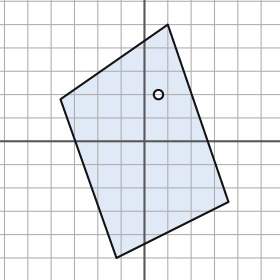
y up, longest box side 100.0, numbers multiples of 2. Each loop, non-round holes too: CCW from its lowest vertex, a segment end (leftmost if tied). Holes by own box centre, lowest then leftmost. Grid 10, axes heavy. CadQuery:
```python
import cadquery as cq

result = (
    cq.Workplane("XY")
    .moveTo(-12.0, -50.0)
    .lineTo(36.0, -26.0)
    .lineTo(10.0, 50.0)
    .lineTo(-36.0, 18.0)
    .close()
    .moveTo(6.0, 20.0)
    .circle(2.0)
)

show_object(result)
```